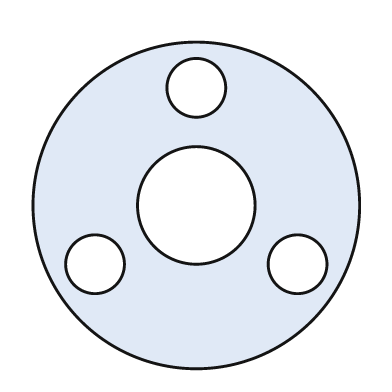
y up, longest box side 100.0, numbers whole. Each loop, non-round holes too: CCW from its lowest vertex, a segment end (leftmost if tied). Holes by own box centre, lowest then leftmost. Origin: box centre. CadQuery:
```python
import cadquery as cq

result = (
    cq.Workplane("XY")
    .moveTo(0.0, 0.0)
    .circle(50.0)
    .moveTo(-31.0, -18.0)
    .circle(9.0)
    .moveTo(31.0, -18.0)
    .circle(9.0)
    .moveTo(0.0, 0.0)
    .circle(18.0)
    .moveTo(0.0, 36.0)
    .circle(9.0)
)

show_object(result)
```